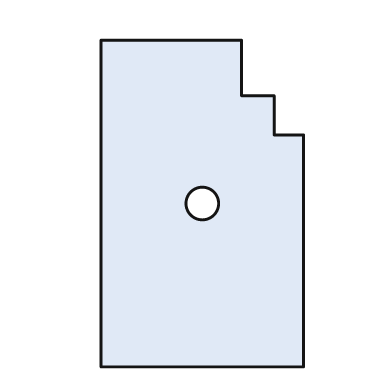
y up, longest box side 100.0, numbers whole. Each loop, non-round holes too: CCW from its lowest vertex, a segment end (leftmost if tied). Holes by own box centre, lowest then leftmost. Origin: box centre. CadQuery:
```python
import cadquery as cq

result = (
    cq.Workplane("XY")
    .moveTo(-31.0, -50.0)
    .lineTo(31.0, -50.0)
    .lineTo(31.0, 21.0)
    .lineTo(22.0, 21.0)
    .lineTo(22.0, 33.0)
    .lineTo(12.0, 33.0)
    .lineTo(12.0, 50.0)
    .lineTo(-31.0, 50.0)
    .close()
    .moveTo(0.0, 0.0)
    .circle(5.0)
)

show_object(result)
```